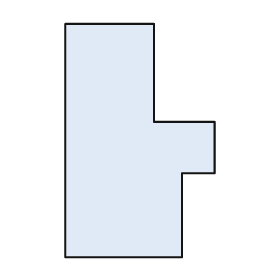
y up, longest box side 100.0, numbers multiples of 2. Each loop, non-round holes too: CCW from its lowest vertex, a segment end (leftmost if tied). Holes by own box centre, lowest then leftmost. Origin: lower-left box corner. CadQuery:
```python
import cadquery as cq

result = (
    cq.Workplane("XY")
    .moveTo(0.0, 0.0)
    .lineTo(50.0, 0.0)
    .lineTo(50.0, 36.0)
    .lineTo(64.0, 36.0)
    .lineTo(64.0, 58.0)
    .lineTo(38.0, 58.0)
    .lineTo(38.0, 100.0)
    .lineTo(0.0, 100.0)
    .close()
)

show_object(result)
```